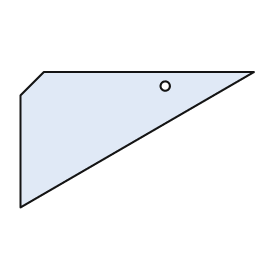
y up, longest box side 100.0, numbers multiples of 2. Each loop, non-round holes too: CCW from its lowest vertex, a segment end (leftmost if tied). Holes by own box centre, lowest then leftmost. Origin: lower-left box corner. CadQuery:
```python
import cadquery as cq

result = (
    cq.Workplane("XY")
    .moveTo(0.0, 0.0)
    .lineTo(100.0, 58.0)
    .lineTo(10.0, 58.0)
    .lineTo(0.0, 48.0)
    .close()
    .moveTo(62.0, 52.0)
    .circle(2.0)
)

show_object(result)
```